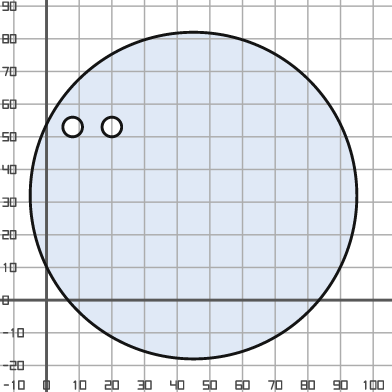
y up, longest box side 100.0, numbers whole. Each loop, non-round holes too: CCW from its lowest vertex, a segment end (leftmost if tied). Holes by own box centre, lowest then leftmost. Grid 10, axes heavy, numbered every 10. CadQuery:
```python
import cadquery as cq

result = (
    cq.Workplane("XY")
    .moveTo(45.0, 32.0)
    .circle(50.0)
    .moveTo(8.0, 53.0)
    .circle(3.0)
    .moveTo(20.0, 53.0)
    .circle(3.0)
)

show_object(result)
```